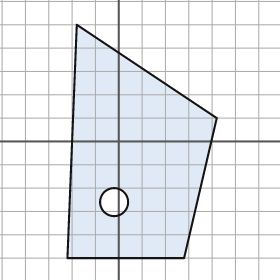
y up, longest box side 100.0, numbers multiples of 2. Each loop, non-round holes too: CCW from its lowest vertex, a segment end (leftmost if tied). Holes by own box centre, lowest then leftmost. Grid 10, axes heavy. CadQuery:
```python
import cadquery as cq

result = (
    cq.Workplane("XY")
    .moveTo(-22.0, -50.0)
    .lineTo(28.0, -50.0)
    .lineTo(42.0, 10.0)
    .lineTo(-18.0, 50.0)
    .close()
    .moveTo(-2.0, -26.0)
    .circle(6.0)
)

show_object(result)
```